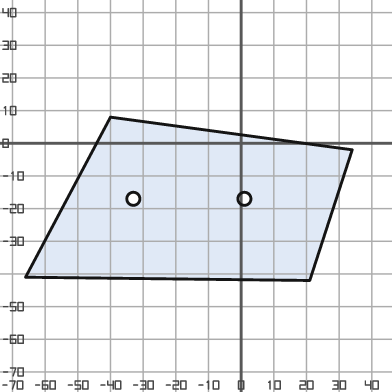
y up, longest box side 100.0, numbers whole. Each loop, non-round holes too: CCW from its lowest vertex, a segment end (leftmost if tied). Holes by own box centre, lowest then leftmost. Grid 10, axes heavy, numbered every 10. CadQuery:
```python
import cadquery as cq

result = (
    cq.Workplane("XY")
    .moveTo(21.0, -42.0)
    .lineTo(34.0, -2.0)
    .lineTo(-40.0, 8.0)
    .lineTo(-66.0, -41.0)
    .close()
    .moveTo(-33.0, -17.0)
    .circle(2.0)
    .moveTo(1.0, -17.0)
    .circle(2.0)
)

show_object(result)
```